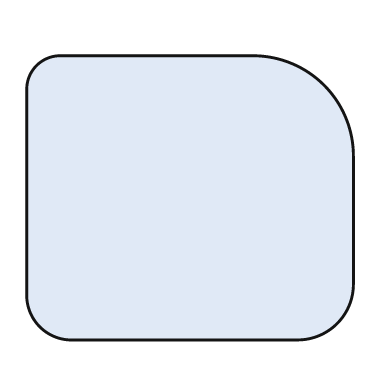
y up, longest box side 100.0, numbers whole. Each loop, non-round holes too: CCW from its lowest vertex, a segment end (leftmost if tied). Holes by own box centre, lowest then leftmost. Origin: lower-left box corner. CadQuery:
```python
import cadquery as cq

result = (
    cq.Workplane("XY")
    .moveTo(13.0, 0.0)
    .lineTo(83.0, 0.0)
    .threePointArc((95.0, 5.0), (100.0, 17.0))
    .lineTo(100.0, 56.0)
    .threePointArc((91.0, 78.0), (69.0, 87.0))
    .lineTo(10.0, 87.0)
    .threePointArc((3.0, 84.0), (0.0, 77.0))
    .lineTo(0.0, 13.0)
    .threePointArc((4.0, 4.0), (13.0, 0.0))
    .close()
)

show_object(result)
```